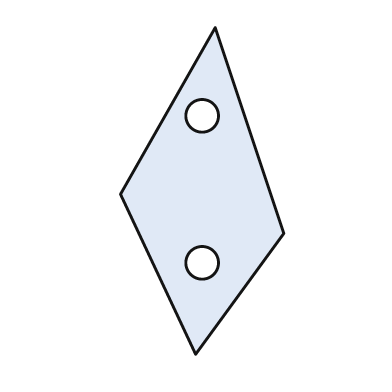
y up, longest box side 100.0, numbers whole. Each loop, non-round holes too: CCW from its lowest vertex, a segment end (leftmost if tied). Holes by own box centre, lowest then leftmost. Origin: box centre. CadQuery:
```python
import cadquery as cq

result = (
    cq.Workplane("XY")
    .moveTo(-2.0, -50.0)
    .lineTo(25.0, -13.0)
    .lineTo(4.0, 50.0)
    .lineTo(-25.0, -1.0)
    .close()
    .moveTo(0.0, -22.0)
    .circle(5.0)
    .moveTo(0.0, 23.0)
    .circle(5.0)
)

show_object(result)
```